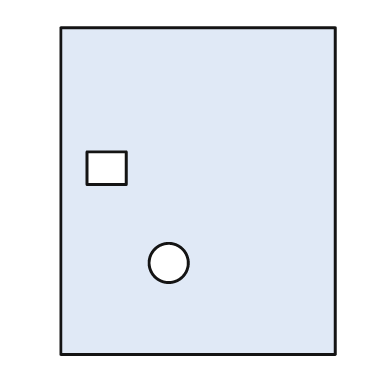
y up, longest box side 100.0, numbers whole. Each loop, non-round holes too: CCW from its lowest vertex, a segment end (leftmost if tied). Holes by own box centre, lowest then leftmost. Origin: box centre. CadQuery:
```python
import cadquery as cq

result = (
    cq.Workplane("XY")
    .moveTo(-42.0, -50.0)
    .lineTo(42.0, -50.0)
    .lineTo(42.0, 50.0)
    .lineTo(-42.0, 50.0)
    .close()
    .moveTo(-9.0, -22.0)
    .circle(6.0)
    .moveTo(-34.0, 2.0)
    .lineTo(-22.0, 2.0)
    .lineTo(-22.0, 12.0)
    .lineTo(-34.0, 12.0)
    .close()
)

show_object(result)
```